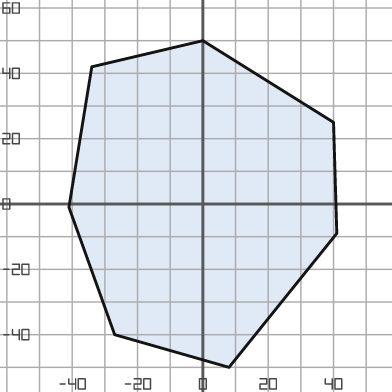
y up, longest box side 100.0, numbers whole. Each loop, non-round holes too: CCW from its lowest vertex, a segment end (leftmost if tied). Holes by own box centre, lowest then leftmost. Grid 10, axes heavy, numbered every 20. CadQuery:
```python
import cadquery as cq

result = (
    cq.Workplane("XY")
    .moveTo(8.0, -50.0)
    .lineTo(41.0, -9.0)
    .lineTo(40.0, 25.0)
    .lineTo(0.0, 50.0)
    .lineTo(-34.0, 42.0)
    .lineTo(-41.0, -1.0)
    .lineTo(-27.0, -40.0)
    .close()
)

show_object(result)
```